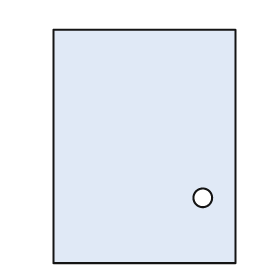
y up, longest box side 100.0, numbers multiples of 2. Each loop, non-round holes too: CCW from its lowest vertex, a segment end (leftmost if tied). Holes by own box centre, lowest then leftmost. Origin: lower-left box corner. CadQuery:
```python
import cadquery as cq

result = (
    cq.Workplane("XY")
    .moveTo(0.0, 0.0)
    .lineTo(78.0, 0.0)
    .lineTo(78.0, 100.0)
    .lineTo(0.0, 100.0)
    .close()
    .moveTo(64.0, 28.0)
    .circle(4.0)
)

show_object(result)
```